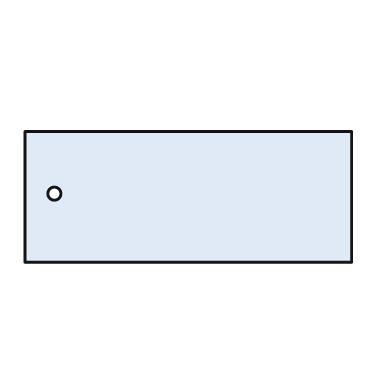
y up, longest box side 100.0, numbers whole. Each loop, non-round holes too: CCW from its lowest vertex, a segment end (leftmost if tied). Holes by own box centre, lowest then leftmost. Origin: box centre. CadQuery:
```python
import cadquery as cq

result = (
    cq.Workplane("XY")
    .moveTo(-50.0, -20.0)
    .lineTo(50.0, -20.0)
    .lineTo(50.0, 20.0)
    .lineTo(-50.0, 20.0)
    .close()
    .moveTo(-41.0, 1.0)
    .circle(2.0)
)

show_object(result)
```